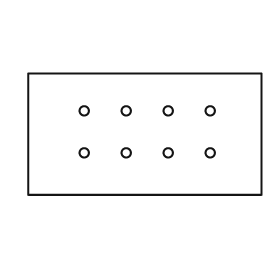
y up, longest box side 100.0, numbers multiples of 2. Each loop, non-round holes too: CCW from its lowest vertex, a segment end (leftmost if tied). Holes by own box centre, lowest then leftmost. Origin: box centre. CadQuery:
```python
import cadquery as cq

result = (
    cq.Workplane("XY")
    .moveTo(-50.0, -26.0)
    .lineTo(50.0, -26.0)
    .lineTo(50.0, 26.0)
    .lineTo(-50.0, 26.0)
    .close()
    .moveTo(-26.0, -8.0)
    .circle(2.0)
    .moveTo(-8.0, -8.0)
    .circle(2.0)
    .moveTo(10.0, -8.0)
    .circle(2.0)
    .moveTo(28.0, -8.0)
    .circle(2.0)
    .moveTo(-26.0, 10.0)
    .circle(2.0)
    .moveTo(-8.0, 10.0)
    .circle(2.0)
    .moveTo(10.0, 10.0)
    .circle(2.0)
    .moveTo(28.0, 10.0)
    .circle(2.0)
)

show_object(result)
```